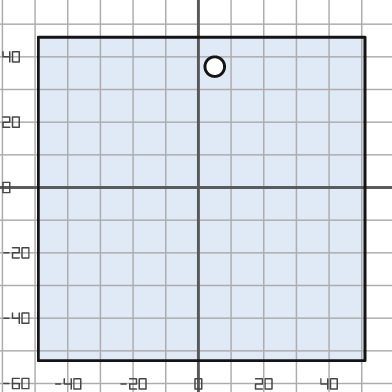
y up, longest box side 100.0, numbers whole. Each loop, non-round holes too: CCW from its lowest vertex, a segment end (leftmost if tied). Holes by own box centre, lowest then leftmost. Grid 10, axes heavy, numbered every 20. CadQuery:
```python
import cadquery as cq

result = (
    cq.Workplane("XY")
    .moveTo(-49.0, -53.0)
    .lineTo(51.0, -53.0)
    .lineTo(51.0, 46.0)
    .lineTo(-49.0, 46.0)
    .close()
    .moveTo(5.0, 37.0)
    .circle(3.0)
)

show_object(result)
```